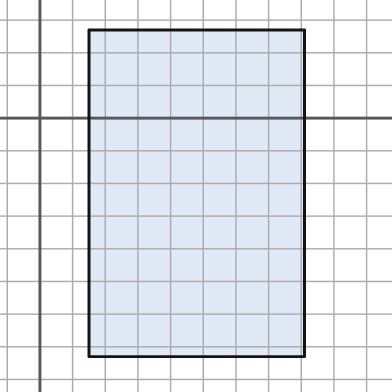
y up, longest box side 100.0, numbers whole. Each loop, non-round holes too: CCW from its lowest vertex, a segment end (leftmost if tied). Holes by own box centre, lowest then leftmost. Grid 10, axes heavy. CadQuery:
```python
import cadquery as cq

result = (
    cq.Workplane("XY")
    .moveTo(15.0, -73.0)
    .lineTo(81.0, -73.0)
    .lineTo(81.0, 27.0)
    .lineTo(15.0, 27.0)
    .close()
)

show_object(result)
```